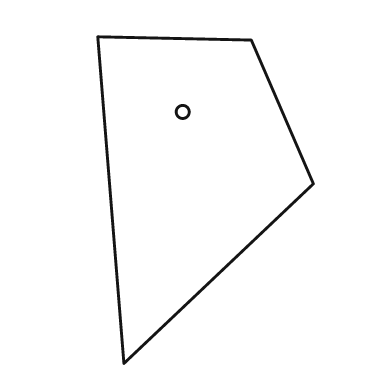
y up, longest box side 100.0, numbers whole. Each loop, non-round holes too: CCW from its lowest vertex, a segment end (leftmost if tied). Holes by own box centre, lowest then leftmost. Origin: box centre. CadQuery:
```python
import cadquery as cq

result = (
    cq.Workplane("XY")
    .moveTo(-25.0, -50.0)
    .lineTo(33.0, 5.0)
    .lineTo(14.0, 49.0)
    .lineTo(-33.0, 50.0)
    .close()
    .moveTo(-7.0, 27.0)
    .circle(2.0)
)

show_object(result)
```